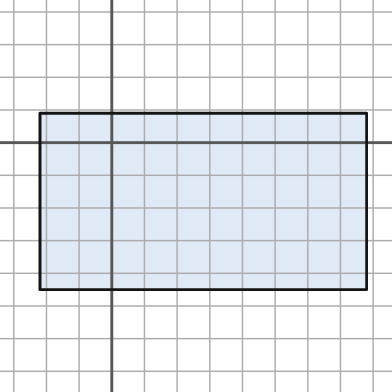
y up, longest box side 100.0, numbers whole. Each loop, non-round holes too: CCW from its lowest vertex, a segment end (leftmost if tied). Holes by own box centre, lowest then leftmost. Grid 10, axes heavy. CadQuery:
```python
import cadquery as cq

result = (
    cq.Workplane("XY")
    .moveTo(-22.0, -45.0)
    .lineTo(78.0, -45.0)
    .lineTo(78.0, 9.0)
    .lineTo(-22.0, 9.0)
    .close()
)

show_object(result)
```